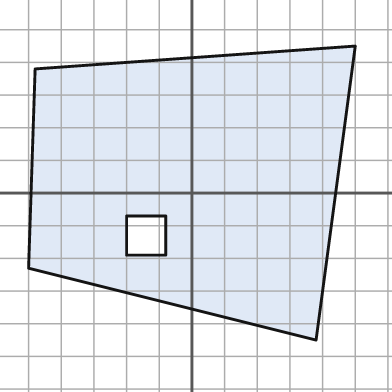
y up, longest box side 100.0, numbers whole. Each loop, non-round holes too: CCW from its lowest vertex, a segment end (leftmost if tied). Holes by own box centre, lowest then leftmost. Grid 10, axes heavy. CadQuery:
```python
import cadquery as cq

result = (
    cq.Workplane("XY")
    .moveTo(38.0, -45.0)
    .lineTo(50.0, 45.0)
    .lineTo(-48.0, 38.0)
    .lineTo(-50.0, -23.0)
    .close()
    .moveTo(-20.0, -19.0)
    .lineTo(-8.0, -19.0)
    .lineTo(-8.0, -7.0)
    .lineTo(-20.0, -7.0)
    .close()
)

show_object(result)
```